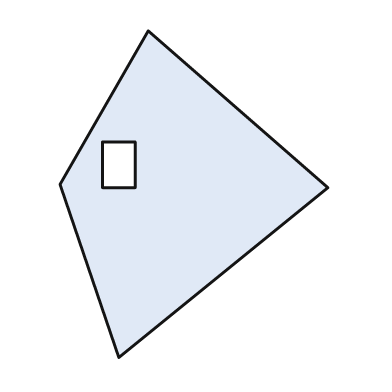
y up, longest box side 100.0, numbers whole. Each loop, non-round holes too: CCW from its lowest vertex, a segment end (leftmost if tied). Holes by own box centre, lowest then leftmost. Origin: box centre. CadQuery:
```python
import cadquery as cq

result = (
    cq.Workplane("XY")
    .moveTo(-23.0, -50.0)
    .lineTo(41.0, 2.0)
    .lineTo(-14.0, 50.0)
    .lineTo(-41.0, 3.0)
    .close()
    .moveTo(-28.0, 2.0)
    .lineTo(-18.0, 2.0)
    .lineTo(-18.0, 16.0)
    .lineTo(-28.0, 16.0)
    .close()
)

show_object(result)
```